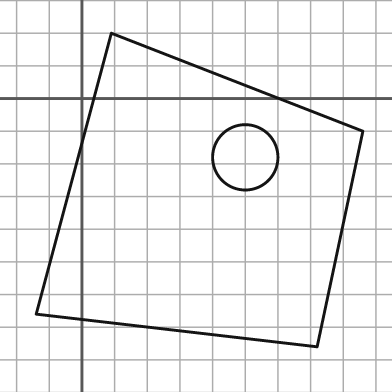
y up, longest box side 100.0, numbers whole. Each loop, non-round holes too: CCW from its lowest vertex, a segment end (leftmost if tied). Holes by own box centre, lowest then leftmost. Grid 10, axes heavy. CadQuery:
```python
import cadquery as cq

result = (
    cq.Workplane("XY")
    .moveTo(72.0, -76.0)
    .lineTo(86.0, -10.0)
    .lineTo(9.0, 20.0)
    .lineTo(-14.0, -66.0)
    .close()
    .moveTo(50.0, -18.0)
    .circle(10.0)
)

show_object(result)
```